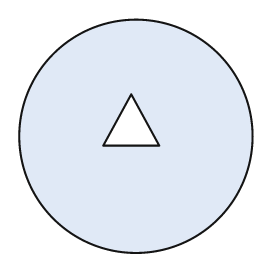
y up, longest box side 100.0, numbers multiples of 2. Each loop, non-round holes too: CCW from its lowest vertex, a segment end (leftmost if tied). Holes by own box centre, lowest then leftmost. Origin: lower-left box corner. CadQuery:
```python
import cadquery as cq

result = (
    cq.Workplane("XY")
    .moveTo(50.0, 50.0)
    .circle(50.0)
    .moveTo(36.0, 46.0)
    .lineTo(60.0, 46.0)
    .lineTo(48.0, 68.0)
    .close()
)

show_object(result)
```